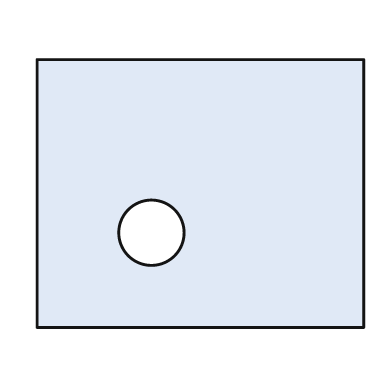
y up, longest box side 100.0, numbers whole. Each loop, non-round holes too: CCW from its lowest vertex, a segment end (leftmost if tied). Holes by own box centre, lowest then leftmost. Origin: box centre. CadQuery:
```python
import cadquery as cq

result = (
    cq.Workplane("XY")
    .moveTo(-50.0, -41.0)
    .lineTo(50.0, -41.0)
    .lineTo(50.0, 41.0)
    .lineTo(-50.0, 41.0)
    .close()
    .moveTo(-15.0, -12.0)
    .circle(10.0)
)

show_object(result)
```